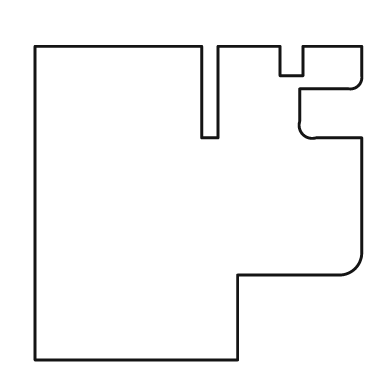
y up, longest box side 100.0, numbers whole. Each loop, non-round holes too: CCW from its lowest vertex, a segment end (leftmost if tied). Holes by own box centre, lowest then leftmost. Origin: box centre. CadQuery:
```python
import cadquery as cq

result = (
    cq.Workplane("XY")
    .moveTo(-50.0, -48.0)
    .lineTo(12.0, -48.0)
    .lineTo(12.0, -22.0)
    .lineTo(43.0, -22.0)
    .threePointArc((48.0, -20.0), (50.0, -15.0))
    .lineTo(50.0, 20.0)
    .lineTo(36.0, 20.0)
    .threePointArc((32.0, 21.0), (31.0, 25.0))
    .lineTo(31.0, 35.0)
    .lineTo(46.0, 35.0)
    .threePointArc((49.0, 36.0), (50.0, 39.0))
    .lineTo(50.0, 48.0)
    .lineTo(32.0, 48.0)
    .lineTo(32.0, 39.0)
    .lineTo(25.0, 39.0)
    .lineTo(25.0, 48.0)
    .lineTo(6.0, 48.0)
    .lineTo(6.0, 20.0)
    .lineTo(1.0, 20.0)
    .lineTo(1.0, 48.0)
    .lineTo(-50.0, 48.0)
    .close()
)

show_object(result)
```